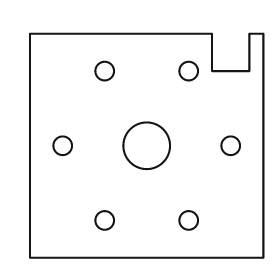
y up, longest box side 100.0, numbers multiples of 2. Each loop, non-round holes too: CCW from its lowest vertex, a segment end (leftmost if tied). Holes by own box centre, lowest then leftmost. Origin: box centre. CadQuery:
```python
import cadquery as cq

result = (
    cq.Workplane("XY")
    .moveTo(-50.0, -48.0)
    .lineTo(50.0, -48.0)
    .lineTo(50.0, 48.0)
    .lineTo(44.0, 48.0)
    .lineTo(44.0, 32.0)
    .lineTo(28.0, 32.0)
    .lineTo(28.0, 48.0)
    .lineTo(-50.0, 48.0)
    .close()
    .moveTo(-18.0, -32.0)
    .circle(4.0)
    .moveTo(18.0, -32.0)
    .circle(4.0)
    .moveTo(-36.0, 0.0)
    .circle(4.0)
    .moveTo(0.0, 0.0)
    .circle(10.0)
    .moveTo(36.0, 0.0)
    .circle(4.0)
    .moveTo(-18.0, 32.0)
    .circle(4.0)
    .moveTo(18.0, 32.0)
    .circle(4.0)
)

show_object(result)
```